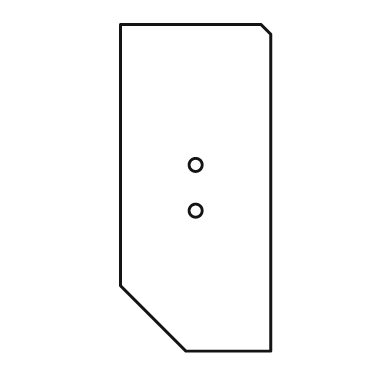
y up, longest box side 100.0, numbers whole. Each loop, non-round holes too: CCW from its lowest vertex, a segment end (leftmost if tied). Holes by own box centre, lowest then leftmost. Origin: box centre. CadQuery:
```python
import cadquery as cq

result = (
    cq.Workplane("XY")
    .moveTo(-3.0, -50.0)
    .lineTo(23.0, -50.0)
    .lineTo(23.0, 47.0)
    .lineTo(20.0, 50.0)
    .lineTo(-23.0, 50.0)
    .lineTo(-23.0, -30.0)
    .close()
    .moveTo(0.0, -7.0)
    .circle(2.0)
    .moveTo(0.0, 7.0)
    .circle(2.0)
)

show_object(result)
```